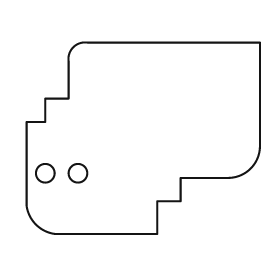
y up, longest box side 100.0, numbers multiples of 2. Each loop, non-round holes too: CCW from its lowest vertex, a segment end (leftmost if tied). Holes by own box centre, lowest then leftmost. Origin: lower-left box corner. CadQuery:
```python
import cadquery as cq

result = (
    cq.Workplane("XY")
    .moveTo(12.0, 0.0)
    .lineTo(56.0, 0.0)
    .lineTo(56.0, 14.0)
    .lineTo(66.0, 14.0)
    .lineTo(66.0, 24.0)
    .lineTo(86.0, 24.0)
    .threePointArc((96.0, 28.0), (100.0, 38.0))
    .lineTo(100.0, 82.0)
    .lineTo(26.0, 82.0)
    .threePointArc((20.0, 80.0), (18.0, 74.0))
    .lineTo(18.0, 58.0)
    .lineTo(8.0, 58.0)
    .lineTo(8.0, 48.0)
    .lineTo(0.0, 48.0)
    .lineTo(0.0, 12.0)
    .threePointArc((4.0, 4.0), (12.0, 0.0))
    .close()
    .moveTo(8.0, 26.0)
    .circle(4.0)
    .moveTo(22.0, 26.0)
    .circle(4.0)
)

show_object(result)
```